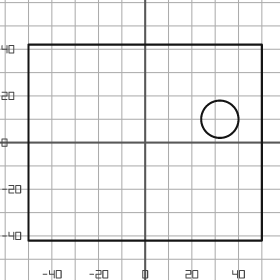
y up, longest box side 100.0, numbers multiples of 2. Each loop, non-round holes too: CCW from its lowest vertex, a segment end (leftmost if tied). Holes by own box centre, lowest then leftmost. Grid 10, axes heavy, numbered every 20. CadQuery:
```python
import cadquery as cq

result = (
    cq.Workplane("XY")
    .moveTo(-50.0, -42.0)
    .lineTo(50.0, -42.0)
    .lineTo(50.0, 42.0)
    .lineTo(-50.0, 42.0)
    .close()
    .moveTo(32.0, 10.0)
    .circle(8.0)
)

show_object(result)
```